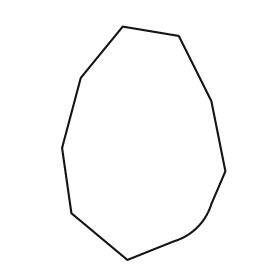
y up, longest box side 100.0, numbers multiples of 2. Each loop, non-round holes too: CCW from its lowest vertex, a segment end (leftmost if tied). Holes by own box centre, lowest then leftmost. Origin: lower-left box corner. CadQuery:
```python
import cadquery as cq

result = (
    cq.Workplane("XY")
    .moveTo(28.0, 0.0)
    .lineTo(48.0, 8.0)
    .threePointArc((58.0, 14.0), (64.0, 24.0))
    .lineTo(70.0, 38.0)
    .lineTo(64.0, 68.0)
    .lineTo(50.0, 96.0)
    .lineTo(26.0, 100.0)
    .lineTo(8.0, 78.0)
    .lineTo(0.0, 48.0)
    .lineTo(4.0, 20.0)
    .close()
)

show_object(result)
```